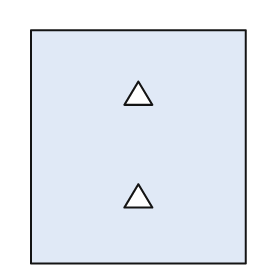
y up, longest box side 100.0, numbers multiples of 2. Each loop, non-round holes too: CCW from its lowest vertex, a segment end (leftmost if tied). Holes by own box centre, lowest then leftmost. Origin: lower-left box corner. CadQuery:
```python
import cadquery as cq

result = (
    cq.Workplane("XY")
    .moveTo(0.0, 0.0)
    .lineTo(92.0, 0.0)
    .lineTo(92.0, 100.0)
    .lineTo(0.0, 100.0)
    .close()
    .moveTo(40.0, 24.0)
    .lineTo(52.0, 24.0)
    .lineTo(46.0, 34.0)
    .close()
    .moveTo(40.0, 68.0)
    .lineTo(52.0, 68.0)
    .lineTo(46.0, 78.0)
    .close()
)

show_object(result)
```